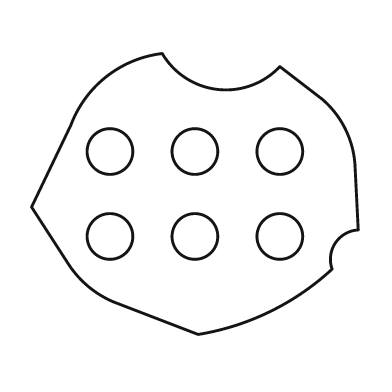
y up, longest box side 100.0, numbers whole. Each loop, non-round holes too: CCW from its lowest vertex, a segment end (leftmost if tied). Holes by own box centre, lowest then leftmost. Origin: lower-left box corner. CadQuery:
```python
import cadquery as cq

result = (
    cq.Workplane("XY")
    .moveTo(51.0, 0.0)
    .threePointArc((73.0, 7.0), (92.0, 20.0))
    .threePointArc((93.0, 28.0), (100.0, 32.0))
    .lineTo(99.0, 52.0)
    .threePointArc((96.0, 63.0), (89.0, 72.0))
    .lineTo(76.0, 82.0)
    .threePointArc((57.0, 75.0), (40.0, 86.0))
    .threePointArc((23.0, 79.0), (12.0, 64.0))
    .lineTo(0.0, 39.0)
    .lineTo(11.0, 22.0)
    .threePointArc((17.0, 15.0), (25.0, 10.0))
    .close()
    .moveTo(24.0, 30.0)
    .circle(7.0)
    .moveTo(50.0, 30.0)
    .circle(7.0)
    .moveTo(76.0, 30.0)
    .circle(7.0)
    .moveTo(24.0, 56.0)
    .circle(7.0)
    .moveTo(50.0, 56.0)
    .circle(7.0)
    .moveTo(76.0, 56.0)
    .circle(7.0)
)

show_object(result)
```